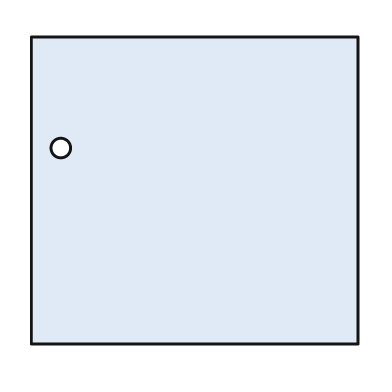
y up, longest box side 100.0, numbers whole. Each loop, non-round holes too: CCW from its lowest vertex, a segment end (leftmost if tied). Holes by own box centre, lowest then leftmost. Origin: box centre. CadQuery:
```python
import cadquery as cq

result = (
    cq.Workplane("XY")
    .moveTo(-50.0, -47.0)
    .lineTo(50.0, -47.0)
    .lineTo(50.0, 47.0)
    .lineTo(-50.0, 47.0)
    .close()
    .moveTo(-41.0, 13.0)
    .circle(3.0)
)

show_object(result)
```